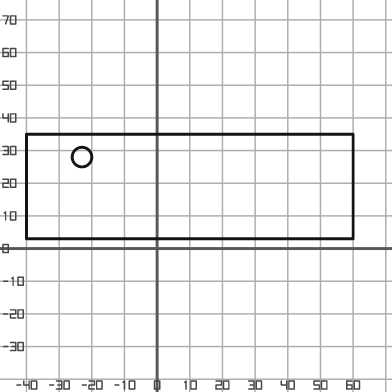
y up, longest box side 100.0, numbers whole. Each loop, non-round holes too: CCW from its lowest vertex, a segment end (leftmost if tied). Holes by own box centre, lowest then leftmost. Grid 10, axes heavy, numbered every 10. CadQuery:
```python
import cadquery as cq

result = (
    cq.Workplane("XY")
    .moveTo(-40.0, 3.0)
    .lineTo(60.0, 3.0)
    .lineTo(60.0, 35.0)
    .lineTo(-40.0, 35.0)
    .close()
    .moveTo(-23.0, 28.0)
    .circle(3.0)
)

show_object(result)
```